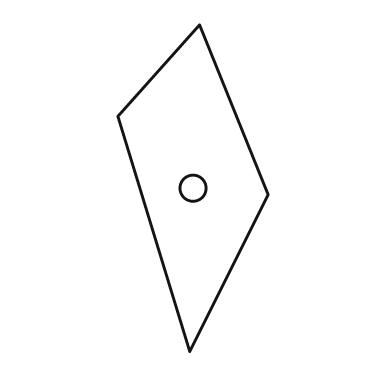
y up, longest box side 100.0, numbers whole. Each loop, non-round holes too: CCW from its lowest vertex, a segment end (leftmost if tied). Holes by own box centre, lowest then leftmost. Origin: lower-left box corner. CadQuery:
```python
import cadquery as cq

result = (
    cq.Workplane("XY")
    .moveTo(22.0, 0.0)
    .lineTo(46.0, 48.0)
    .lineTo(25.0, 100.0)
    .lineTo(0.0, 72.0)
    .close()
    .moveTo(23.0, 50.0)
    .circle(4.0)
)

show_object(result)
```